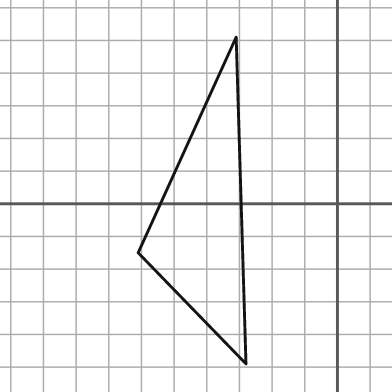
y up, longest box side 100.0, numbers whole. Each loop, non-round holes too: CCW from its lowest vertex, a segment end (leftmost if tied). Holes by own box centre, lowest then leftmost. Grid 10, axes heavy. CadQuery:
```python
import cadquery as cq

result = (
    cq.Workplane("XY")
    .moveTo(-28.0, -49.0)
    .lineTo(-31.0, 51.0)
    .lineTo(-61.0, -15.0)
    .close()
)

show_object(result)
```